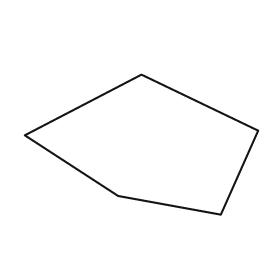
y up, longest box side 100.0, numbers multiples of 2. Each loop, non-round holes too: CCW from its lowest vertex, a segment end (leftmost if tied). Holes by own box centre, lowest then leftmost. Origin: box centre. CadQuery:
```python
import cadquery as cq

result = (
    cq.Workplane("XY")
    .moveTo(34.0, -30.0)
    .lineTo(50.0, 6.0)
    .lineTo(0.0, 30.0)
    .lineTo(-50.0, 4.0)
    .lineTo(-10.0, -22.0)
    .close()
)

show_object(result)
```